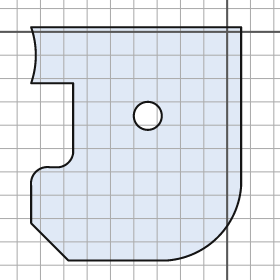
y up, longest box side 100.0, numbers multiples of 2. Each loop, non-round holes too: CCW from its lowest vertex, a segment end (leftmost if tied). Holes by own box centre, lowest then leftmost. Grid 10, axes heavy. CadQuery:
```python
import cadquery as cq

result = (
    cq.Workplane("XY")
    .moveTo(-68.0, -98.0)
    .lineTo(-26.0, -98.0)
    .threePointArc((-4.0, -88.0), (6.0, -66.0))
    .lineTo(6.0, 2.0)
    .lineTo(-84.0, 2.0)
    .threePointArc((-82.0, -10.0), (-84.0, -22.0))
    .lineTo(-66.0, -22.0)
    .lineTo(-66.0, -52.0)
    .threePointArc((-68.0, -56.0), (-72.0, -58.0))
    .lineTo(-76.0, -58.0)
    .threePointArc((-82.0, -60.0), (-84.0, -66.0))
    .lineTo(-84.0, -82.0)
    .close()
    .moveTo(-34.0, -36.0)
    .circle(6.0)
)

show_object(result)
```